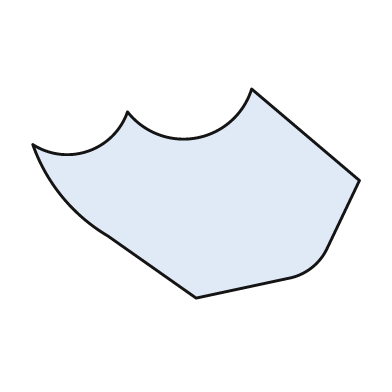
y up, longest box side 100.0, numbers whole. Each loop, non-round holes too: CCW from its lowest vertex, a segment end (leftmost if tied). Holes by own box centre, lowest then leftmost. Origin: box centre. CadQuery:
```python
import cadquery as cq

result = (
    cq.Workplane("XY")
    .moveTo(0.0, -32.0)
    .lineTo(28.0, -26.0)
    .threePointArc((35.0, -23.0), (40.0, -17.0))
    .lineTo(50.0, 4.0)
    .lineTo(17.0, 32.0)
    .threePointArc((0.0, 17.0), (-21.0, 25.0))
    .threePointArc((-33.0, 13.0), (-50.0, 15.0))
    .threePointArc((-41.0, -1.0), (-27.0, -13.0))
    .close()
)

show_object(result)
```